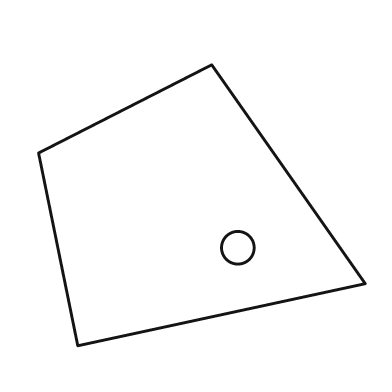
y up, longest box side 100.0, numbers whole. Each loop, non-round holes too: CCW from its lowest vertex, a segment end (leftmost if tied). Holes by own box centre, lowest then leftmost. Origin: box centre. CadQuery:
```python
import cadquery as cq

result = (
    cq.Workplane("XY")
    .moveTo(-38.0, -43.0)
    .lineTo(50.0, -24.0)
    .lineTo(3.0, 43.0)
    .lineTo(-50.0, 16.0)
    .close()
    .moveTo(11.0, -13.0)
    .circle(5.0)
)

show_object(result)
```